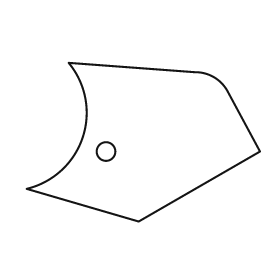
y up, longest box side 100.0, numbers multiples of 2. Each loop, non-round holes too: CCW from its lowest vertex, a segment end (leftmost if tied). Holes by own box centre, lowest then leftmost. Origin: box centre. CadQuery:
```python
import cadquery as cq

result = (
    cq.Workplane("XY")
    .moveTo(-2.0, -34.0)
    .lineTo(50.0, -4.0)
    .lineTo(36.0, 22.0)
    .threePointArc((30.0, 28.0), (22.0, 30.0))
    .lineTo(-32.0, 34.0)
    .threePointArc((-26.0, 2.0), (-50.0, -20.0))
    .close()
    .moveTo(-16.0, -4.0)
    .circle(4.0)
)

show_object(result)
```